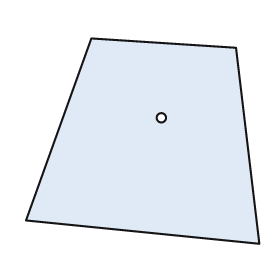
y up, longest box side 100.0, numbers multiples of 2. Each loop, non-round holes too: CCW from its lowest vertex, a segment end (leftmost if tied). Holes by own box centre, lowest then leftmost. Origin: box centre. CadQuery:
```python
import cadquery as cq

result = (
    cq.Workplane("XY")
    .moveTo(50.0, -44.0)
    .lineTo(40.0, 40.0)
    .lineTo(-22.0, 44.0)
    .lineTo(-50.0, -34.0)
    .close()
    .moveTo(8.0, 10.0)
    .circle(2.0)
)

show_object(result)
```